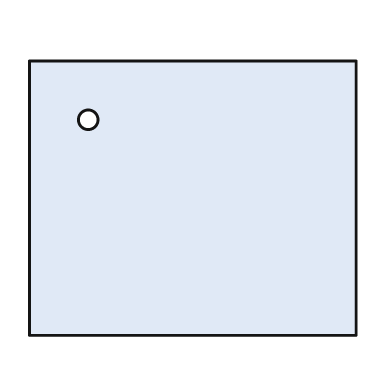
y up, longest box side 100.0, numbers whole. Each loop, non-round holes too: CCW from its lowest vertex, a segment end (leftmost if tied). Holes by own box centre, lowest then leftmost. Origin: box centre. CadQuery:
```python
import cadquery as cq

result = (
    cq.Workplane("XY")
    .moveTo(-50.0, -42.0)
    .lineTo(50.0, -42.0)
    .lineTo(50.0, 42.0)
    .lineTo(-50.0, 42.0)
    .close()
    .moveTo(-32.0, 24.0)
    .circle(3.0)
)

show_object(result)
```